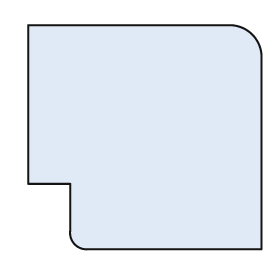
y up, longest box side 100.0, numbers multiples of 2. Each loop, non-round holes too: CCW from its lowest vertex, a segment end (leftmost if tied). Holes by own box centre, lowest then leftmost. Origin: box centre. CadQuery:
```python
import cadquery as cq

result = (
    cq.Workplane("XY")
    .moveTo(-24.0, -48.0)
    .lineTo(50.0, -48.0)
    .lineTo(50.0, 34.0)
    .threePointArc((46.0, 44.0), (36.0, 48.0))
    .lineTo(-50.0, 48.0)
    .lineTo(-50.0, -20.0)
    .lineTo(-32.0, -20.0)
    .lineTo(-32.0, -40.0)
    .threePointArc((-30.0, -46.0), (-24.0, -48.0))
    .close()
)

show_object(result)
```